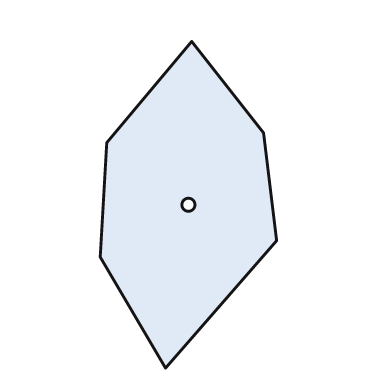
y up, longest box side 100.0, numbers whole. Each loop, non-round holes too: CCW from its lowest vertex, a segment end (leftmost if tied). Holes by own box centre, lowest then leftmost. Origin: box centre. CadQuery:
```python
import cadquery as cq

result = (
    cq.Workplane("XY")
    .moveTo(-7.0, -50.0)
    .lineTo(27.0, -11.0)
    .lineTo(23.0, 22.0)
    .lineTo(1.0, 50.0)
    .lineTo(-25.0, 19.0)
    .lineTo(-27.0, -16.0)
    .close()
    .moveTo(0.0, 0.0)
    .circle(2.0)
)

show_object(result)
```